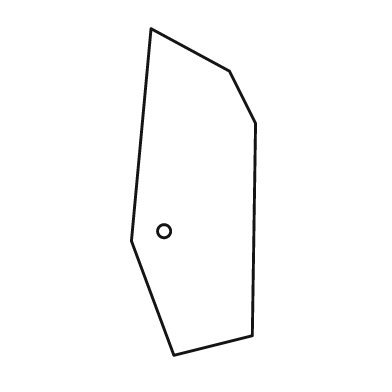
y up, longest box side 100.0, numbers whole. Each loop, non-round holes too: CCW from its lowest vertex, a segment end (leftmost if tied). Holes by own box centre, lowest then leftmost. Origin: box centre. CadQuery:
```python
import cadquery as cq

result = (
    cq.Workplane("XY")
    .moveTo(-6.0, -50.0)
    .lineTo(18.0, -44.0)
    .lineTo(19.0, 21.0)
    .lineTo(11.0, 37.0)
    .lineTo(-13.0, 50.0)
    .lineTo(-19.0, -15.0)
    .close()
    .moveTo(-9.0, -12.0)
    .circle(2.0)
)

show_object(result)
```